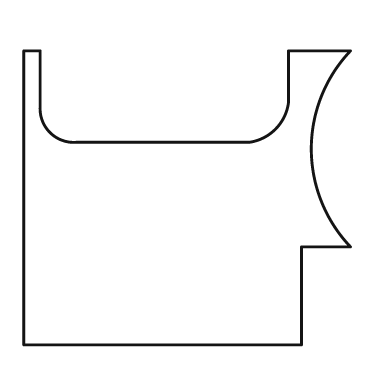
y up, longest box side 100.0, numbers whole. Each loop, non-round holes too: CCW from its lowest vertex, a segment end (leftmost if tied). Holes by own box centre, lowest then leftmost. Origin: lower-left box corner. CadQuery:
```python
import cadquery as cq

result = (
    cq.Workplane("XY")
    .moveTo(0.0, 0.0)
    .lineTo(85.0, 0.0)
    .lineTo(85.0, 30.0)
    .lineTo(100.0, 30.0)
    .threePointArc((88.0, 60.0), (100.0, 90.0))
    .lineTo(81.0, 90.0)
    .lineTo(81.0, 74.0)
    .threePointArc((77.0, 66.0), (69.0, 62.0))
    .lineTo(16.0, 62.0)
    .threePointArc((8.0, 65.0), (5.0, 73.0))
    .lineTo(5.0, 90.0)
    .lineTo(0.0, 90.0)
    .close()
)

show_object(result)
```